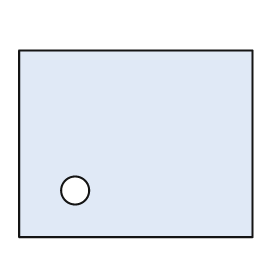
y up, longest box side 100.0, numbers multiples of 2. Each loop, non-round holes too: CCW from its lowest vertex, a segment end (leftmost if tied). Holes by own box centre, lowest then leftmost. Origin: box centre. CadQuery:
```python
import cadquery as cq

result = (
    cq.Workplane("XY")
    .moveTo(-50.0, -40.0)
    .lineTo(50.0, -40.0)
    .lineTo(50.0, 40.0)
    .lineTo(-50.0, 40.0)
    .close()
    .moveTo(-26.0, -20.0)
    .circle(6.0)
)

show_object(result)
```